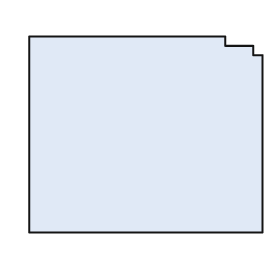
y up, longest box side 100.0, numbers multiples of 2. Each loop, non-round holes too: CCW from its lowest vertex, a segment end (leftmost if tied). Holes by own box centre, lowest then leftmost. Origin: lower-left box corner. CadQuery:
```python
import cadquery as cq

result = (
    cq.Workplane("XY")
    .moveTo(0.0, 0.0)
    .lineTo(100.0, 0.0)
    .lineTo(100.0, 76.0)
    .lineTo(96.0, 76.0)
    .lineTo(96.0, 80.0)
    .lineTo(84.0, 80.0)
    .lineTo(84.0, 84.0)
    .lineTo(0.0, 84.0)
    .close()
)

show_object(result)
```